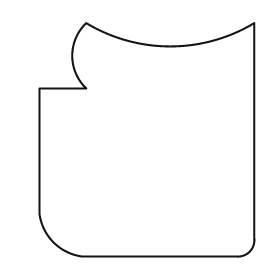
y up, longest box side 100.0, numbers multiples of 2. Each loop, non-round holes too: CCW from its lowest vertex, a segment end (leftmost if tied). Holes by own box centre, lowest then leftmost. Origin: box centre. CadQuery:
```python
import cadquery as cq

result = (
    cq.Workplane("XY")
    .moveTo(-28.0, -50.0)
    .lineTo(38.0, -50.0)
    .threePointArc((44.0, -48.0), (46.0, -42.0))
    .lineTo(46.0, 50.0)
    .threePointArc((10.0, 40.0), (-26.0, 50.0))
    .threePointArc((-32.0, 36.0), (-26.0, 22.0))
    .lineTo(-46.0, 22.0)
    .lineTo(-46.0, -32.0)
    .threePointArc((-40.0, -44.0), (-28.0, -50.0))
    .close()
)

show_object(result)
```